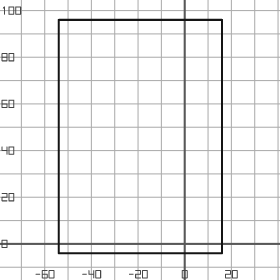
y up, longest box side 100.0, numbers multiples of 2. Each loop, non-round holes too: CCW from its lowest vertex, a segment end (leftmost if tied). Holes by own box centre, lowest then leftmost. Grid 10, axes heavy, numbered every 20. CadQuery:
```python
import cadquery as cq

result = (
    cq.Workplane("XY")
    .moveTo(-54.0, -4.0)
    .lineTo(16.0, -4.0)
    .lineTo(16.0, 96.0)
    .lineTo(-54.0, 96.0)
    .close()
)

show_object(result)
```